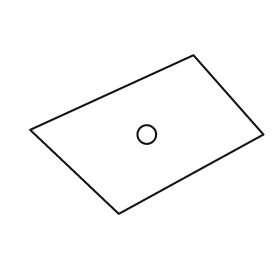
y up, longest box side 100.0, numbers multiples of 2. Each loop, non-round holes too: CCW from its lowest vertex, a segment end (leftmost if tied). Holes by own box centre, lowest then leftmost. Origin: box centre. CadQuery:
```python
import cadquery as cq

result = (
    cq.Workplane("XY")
    .moveTo(-12.0, -34.0)
    .lineTo(50.0, 0.0)
    .lineTo(20.0, 34.0)
    .lineTo(-50.0, 2.0)
    .close()
    .moveTo(0.0, 0.0)
    .circle(4.0)
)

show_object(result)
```